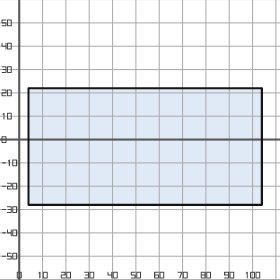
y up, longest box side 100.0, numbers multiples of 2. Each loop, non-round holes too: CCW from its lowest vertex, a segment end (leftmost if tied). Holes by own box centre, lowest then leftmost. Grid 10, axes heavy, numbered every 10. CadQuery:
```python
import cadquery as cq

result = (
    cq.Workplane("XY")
    .moveTo(4.0, -28.0)
    .lineTo(104.0, -28.0)
    .lineTo(104.0, 22.0)
    .lineTo(4.0, 22.0)
    .close()
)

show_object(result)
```